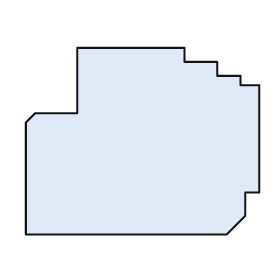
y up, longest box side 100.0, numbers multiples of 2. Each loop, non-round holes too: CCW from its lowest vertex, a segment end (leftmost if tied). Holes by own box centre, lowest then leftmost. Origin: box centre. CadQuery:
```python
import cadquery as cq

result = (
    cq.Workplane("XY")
    .moveTo(-50.0, -40.0)
    .lineTo(36.0, -40.0)
    .lineTo(44.0, -32.0)
    .lineTo(44.0, -22.0)
    .lineTo(50.0, -22.0)
    .lineTo(50.0, 24.0)
    .lineTo(42.0, 24.0)
    .lineTo(42.0, 28.0)
    .lineTo(32.0, 28.0)
    .lineTo(32.0, 34.0)
    .lineTo(18.0, 34.0)
    .lineTo(18.0, 40.0)
    .lineTo(-28.0, 40.0)
    .lineTo(-28.0, 12.0)
    .lineTo(-46.0, 12.0)
    .lineTo(-50.0, 8.0)
    .close()
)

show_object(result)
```